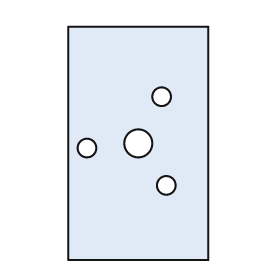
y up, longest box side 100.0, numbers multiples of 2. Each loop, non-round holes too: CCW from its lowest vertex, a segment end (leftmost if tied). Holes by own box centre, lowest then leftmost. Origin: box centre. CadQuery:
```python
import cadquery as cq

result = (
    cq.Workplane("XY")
    .moveTo(-30.0, -50.0)
    .lineTo(30.0, -50.0)
    .lineTo(30.0, 50.0)
    .lineTo(-30.0, 50.0)
    .close()
    .moveTo(12.0, -18.0)
    .circle(4.0)
    .moveTo(-22.0, -2.0)
    .circle(4.0)
    .moveTo(0.0, 0.0)
    .circle(6.0)
    .moveTo(10.0, 20.0)
    .circle(4.0)
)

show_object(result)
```